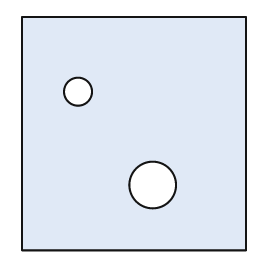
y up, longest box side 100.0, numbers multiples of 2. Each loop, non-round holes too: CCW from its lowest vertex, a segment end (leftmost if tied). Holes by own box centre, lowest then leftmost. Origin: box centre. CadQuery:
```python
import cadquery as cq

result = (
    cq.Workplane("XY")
    .moveTo(-48.0, -50.0)
    .lineTo(48.0, -50.0)
    .lineTo(48.0, 50.0)
    .lineTo(-48.0, 50.0)
    .close()
    .moveTo(8.0, -22.0)
    .circle(10.0)
    .moveTo(-24.0, 18.0)
    .circle(6.0)
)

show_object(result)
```